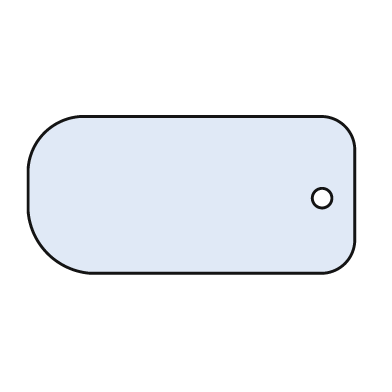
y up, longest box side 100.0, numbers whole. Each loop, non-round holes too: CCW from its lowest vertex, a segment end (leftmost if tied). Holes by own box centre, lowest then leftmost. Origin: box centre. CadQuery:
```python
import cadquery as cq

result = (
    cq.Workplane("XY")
    .moveTo(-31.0, -24.0)
    .lineTo(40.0, -24.0)
    .threePointArc((47.0, -21.0), (50.0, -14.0))
    .lineTo(50.0, 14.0)
    .threePointArc((47.0, 21.0), (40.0, 24.0))
    .lineTo(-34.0, 24.0)
    .threePointArc((-45.0, 19.0), (-50.0, 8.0))
    .lineTo(-50.0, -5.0)
    .threePointArc((-44.0, -18.0), (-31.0, -24.0))
    .close()
    .moveTo(40.0, -1.0)
    .circle(3.0)
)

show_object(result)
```